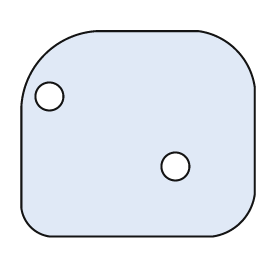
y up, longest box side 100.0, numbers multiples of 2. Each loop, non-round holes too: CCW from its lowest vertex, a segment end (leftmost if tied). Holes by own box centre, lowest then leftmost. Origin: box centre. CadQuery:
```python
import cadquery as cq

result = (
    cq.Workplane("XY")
    .moveTo(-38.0, -44.0)
    .lineTo(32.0, -44.0)
    .threePointArc((44.0, -38.0), (50.0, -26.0))
    .lineTo(50.0, 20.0)
    .threePointArc((42.0, 36.0), (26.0, 44.0))
    .lineTo(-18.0, 44.0)
    .threePointArc((-40.0, 34.0), (-50.0, 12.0))
    .lineTo(-50.0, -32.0)
    .threePointArc((-46.0, -40.0), (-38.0, -44.0))
    .close()
    .moveTo(16.0, -14.0)
    .circle(6.0)
    .moveTo(-38.0, 16.0)
    .circle(6.0)
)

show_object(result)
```